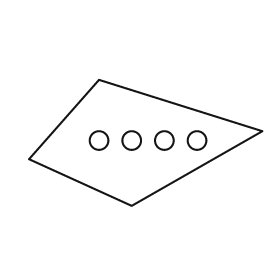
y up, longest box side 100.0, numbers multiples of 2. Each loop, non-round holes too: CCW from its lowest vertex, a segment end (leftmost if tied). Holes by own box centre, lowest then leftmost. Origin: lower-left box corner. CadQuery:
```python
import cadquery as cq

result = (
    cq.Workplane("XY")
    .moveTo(44.0, 0.0)
    .lineTo(100.0, 32.0)
    .lineTo(30.0, 54.0)
    .lineTo(0.0, 20.0)
    .close()
    .moveTo(30.0, 28.0)
    .circle(4.0)
    .moveTo(44.0, 28.0)
    .circle(4.0)
    .moveTo(58.0, 28.0)
    .circle(4.0)
    .moveTo(72.0, 28.0)
    .circle(4.0)
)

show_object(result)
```